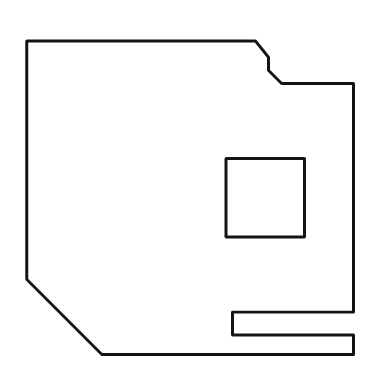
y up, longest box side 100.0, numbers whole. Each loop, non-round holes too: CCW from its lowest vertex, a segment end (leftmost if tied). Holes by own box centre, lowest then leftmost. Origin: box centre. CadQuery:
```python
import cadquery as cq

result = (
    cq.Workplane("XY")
    .moveTo(-27.0, -48.0)
    .lineTo(50.0, -48.0)
    .lineTo(50.0, -42.0)
    .lineTo(13.0, -42.0)
    .lineTo(13.0, -35.0)
    .lineTo(50.0, -35.0)
    .lineTo(50.0, 35.0)
    .lineTo(28.0, 35.0)
    .lineTo(24.0, 39.0)
    .lineTo(24.0, 43.0)
    .lineTo(20.0, 48.0)
    .lineTo(-50.0, 48.0)
    .lineTo(-50.0, -25.0)
    .close()
    .moveTo(11.0, -12.0)
    .lineTo(35.0, -12.0)
    .lineTo(35.0, 12.0)
    .lineTo(11.0, 12.0)
    .close()
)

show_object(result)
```